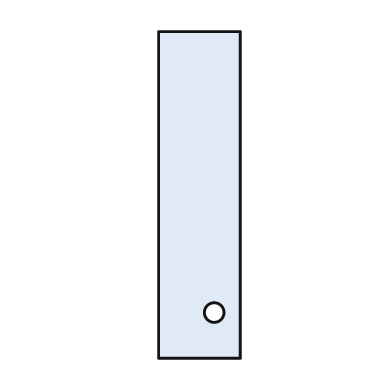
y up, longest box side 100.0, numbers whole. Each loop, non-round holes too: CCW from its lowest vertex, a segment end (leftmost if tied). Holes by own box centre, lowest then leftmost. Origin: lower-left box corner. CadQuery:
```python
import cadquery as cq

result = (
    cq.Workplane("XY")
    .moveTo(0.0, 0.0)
    .lineTo(25.0, 0.0)
    .lineTo(25.0, 100.0)
    .lineTo(0.0, 100.0)
    .close()
    .moveTo(17.0, 14.0)
    .circle(3.0)
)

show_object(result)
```